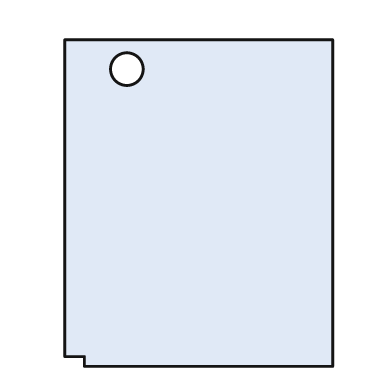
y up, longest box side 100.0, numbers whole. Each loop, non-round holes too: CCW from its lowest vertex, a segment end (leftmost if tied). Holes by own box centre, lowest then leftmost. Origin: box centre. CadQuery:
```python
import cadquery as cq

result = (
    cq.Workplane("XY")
    .moveTo(-35.0, -50.0)
    .lineTo(41.0, -50.0)
    .lineTo(41.0, 50.0)
    .lineTo(-41.0, 50.0)
    .lineTo(-41.0, -47.0)
    .lineTo(-35.0, -47.0)
    .close()
    .moveTo(-22.0, 41.0)
    .circle(5.0)
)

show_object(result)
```